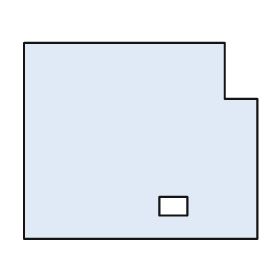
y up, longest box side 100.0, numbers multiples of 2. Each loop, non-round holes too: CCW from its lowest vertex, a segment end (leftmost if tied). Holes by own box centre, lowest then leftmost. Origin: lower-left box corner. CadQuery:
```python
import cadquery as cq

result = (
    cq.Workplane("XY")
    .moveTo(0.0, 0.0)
    .lineTo(100.0, 0.0)
    .lineTo(100.0, 60.0)
    .lineTo(86.0, 60.0)
    .lineTo(86.0, 84.0)
    .lineTo(0.0, 84.0)
    .close()
    .moveTo(58.0, 10.0)
    .lineTo(70.0, 10.0)
    .lineTo(70.0, 18.0)
    .lineTo(58.0, 18.0)
    .close()
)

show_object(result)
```